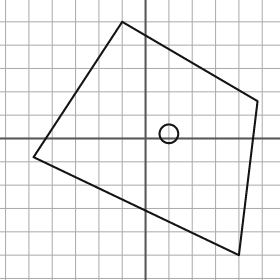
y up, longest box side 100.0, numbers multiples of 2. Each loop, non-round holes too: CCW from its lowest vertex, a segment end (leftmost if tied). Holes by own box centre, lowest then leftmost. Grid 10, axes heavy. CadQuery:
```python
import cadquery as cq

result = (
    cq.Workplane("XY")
    .moveTo(40.0, -50.0)
    .lineTo(48.0, 16.0)
    .lineTo(-10.0, 50.0)
    .lineTo(-48.0, -8.0)
    .close()
    .moveTo(10.0, 2.0)
    .circle(4.0)
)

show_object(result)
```